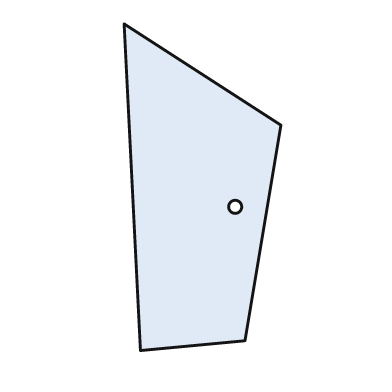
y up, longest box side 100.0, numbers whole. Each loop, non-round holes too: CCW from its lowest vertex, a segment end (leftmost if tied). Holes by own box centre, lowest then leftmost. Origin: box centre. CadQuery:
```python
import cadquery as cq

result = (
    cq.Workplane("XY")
    .moveTo(-19.0, -50.0)
    .lineTo(13.0, -47.0)
    .lineTo(24.0, 19.0)
    .lineTo(-24.0, 50.0)
    .close()
    .moveTo(10.0, -6.0)
    .circle(2.0)
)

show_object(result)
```